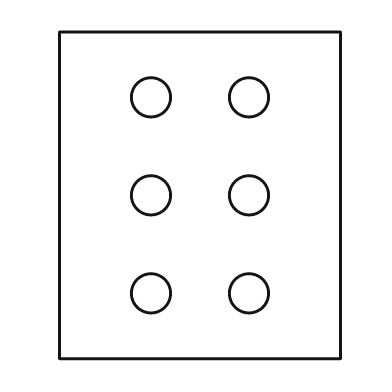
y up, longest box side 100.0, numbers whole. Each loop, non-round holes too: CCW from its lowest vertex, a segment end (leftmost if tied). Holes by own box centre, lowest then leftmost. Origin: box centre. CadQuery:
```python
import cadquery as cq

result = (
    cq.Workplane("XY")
    .moveTo(-43.0, -50.0)
    .lineTo(43.0, -50.0)
    .lineTo(43.0, 50.0)
    .lineTo(-43.0, 50.0)
    .close()
    .moveTo(-15.0, -30.0)
    .circle(6.0)
    .moveTo(15.0, -30.0)
    .circle(6.0)
    .moveTo(-15.0, 0.0)
    .circle(6.0)
    .moveTo(15.0, 0.0)
    .circle(6.0)
    .moveTo(-15.0, 30.0)
    .circle(6.0)
    .moveTo(15.0, 30.0)
    .circle(6.0)
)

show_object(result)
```